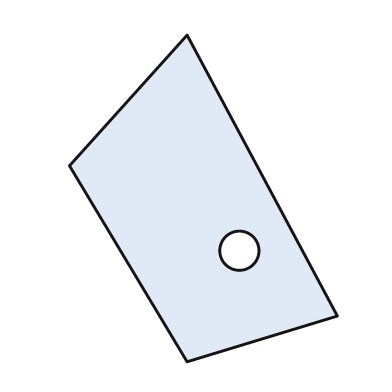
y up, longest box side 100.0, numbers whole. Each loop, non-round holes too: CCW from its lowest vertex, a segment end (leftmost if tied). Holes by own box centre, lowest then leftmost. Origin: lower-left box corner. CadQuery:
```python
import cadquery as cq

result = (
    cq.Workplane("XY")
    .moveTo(36.0, 0.0)
    .lineTo(82.0, 14.0)
    .lineTo(36.0, 100.0)
    .lineTo(0.0, 60.0)
    .close()
    .moveTo(52.0, 34.0)
    .circle(6.0)
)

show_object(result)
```